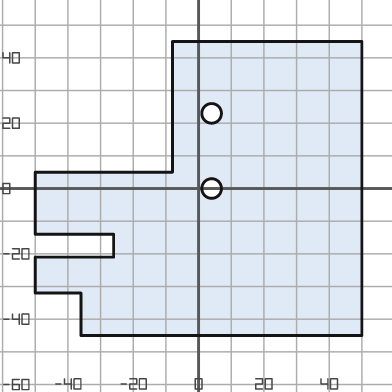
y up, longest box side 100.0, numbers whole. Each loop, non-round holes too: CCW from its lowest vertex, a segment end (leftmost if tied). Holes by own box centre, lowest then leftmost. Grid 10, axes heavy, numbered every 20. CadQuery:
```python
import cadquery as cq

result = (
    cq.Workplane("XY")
    .moveTo(-36.0, -45.0)
    .lineTo(50.0, -45.0)
    .lineTo(50.0, 45.0)
    .lineTo(-8.0, 45.0)
    .lineTo(-8.0, 5.0)
    .lineTo(-50.0, 5.0)
    .lineTo(-50.0, -14.0)
    .lineTo(-26.0, -14.0)
    .lineTo(-26.0, -21.0)
    .lineTo(-50.0, -21.0)
    .lineTo(-50.0, -32.0)
    .lineTo(-36.0, -32.0)
    .close()
    .moveTo(4.0, 0.0)
    .circle(3.0)
    .moveTo(4.0, 23.0)
    .circle(3.0)
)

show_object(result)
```